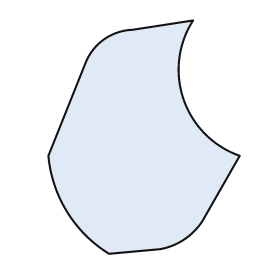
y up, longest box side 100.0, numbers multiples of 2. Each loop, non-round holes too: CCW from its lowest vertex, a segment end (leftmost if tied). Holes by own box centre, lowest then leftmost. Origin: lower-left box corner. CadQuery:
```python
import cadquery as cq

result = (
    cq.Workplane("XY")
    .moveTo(26.0, 0.0)
    .lineTo(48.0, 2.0)
    .threePointArc((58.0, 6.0), (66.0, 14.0))
    .lineTo(82.0, 42.0)
    .threePointArc((58.0, 66.0), (62.0, 100.0))
    .lineTo(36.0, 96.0)
    .threePointArc((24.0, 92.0), (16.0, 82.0))
    .lineTo(0.0, 42.0)
    .threePointArc((8.0, 18.0), (26.0, 0.0))
    .close()
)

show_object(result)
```